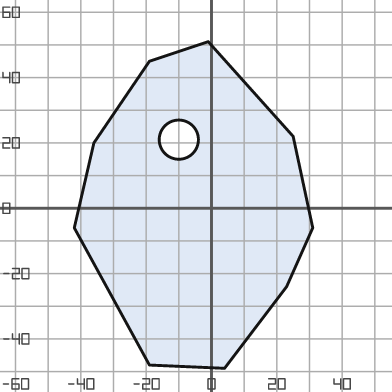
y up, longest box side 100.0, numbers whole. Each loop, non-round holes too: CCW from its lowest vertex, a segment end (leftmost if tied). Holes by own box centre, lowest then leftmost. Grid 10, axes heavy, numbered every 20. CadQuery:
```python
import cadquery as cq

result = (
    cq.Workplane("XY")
    .moveTo(4.0, -49.0)
    .lineTo(23.0, -24.0)
    .lineTo(31.0, -6.0)
    .lineTo(25.0, 22.0)
    .lineTo(-1.0, 51.0)
    .lineTo(-19.0, 45.0)
    .lineTo(-36.0, 20.0)
    .lineTo(-42.0, -6.0)
    .lineTo(-19.0, -48.0)
    .close()
    .moveTo(-10.0, 21.0)
    .circle(6.0)
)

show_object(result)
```